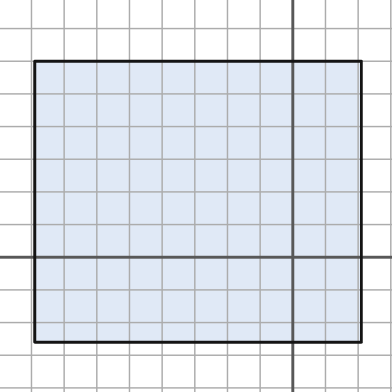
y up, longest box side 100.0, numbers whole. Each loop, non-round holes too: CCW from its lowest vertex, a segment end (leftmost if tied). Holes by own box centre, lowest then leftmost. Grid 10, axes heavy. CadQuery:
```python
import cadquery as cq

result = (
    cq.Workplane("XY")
    .moveTo(-79.0, -26.0)
    .lineTo(21.0, -26.0)
    .lineTo(21.0, 60.0)
    .lineTo(-79.0, 60.0)
    .close()
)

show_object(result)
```